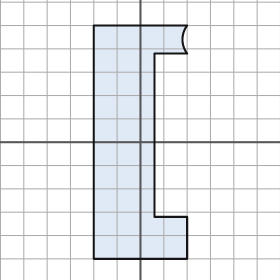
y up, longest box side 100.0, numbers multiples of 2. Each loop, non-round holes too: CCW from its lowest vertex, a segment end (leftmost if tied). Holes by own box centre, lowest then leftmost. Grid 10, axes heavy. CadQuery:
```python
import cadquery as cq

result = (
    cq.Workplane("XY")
    .moveTo(-20.0, -50.0)
    .lineTo(20.0, -50.0)
    .lineTo(20.0, -32.0)
    .lineTo(6.0, -32.0)
    .lineTo(6.0, 38.0)
    .lineTo(20.0, 38.0)
    .threePointArc((18.0, 44.0), (20.0, 50.0))
    .lineTo(-20.0, 50.0)
    .close()
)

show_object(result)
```